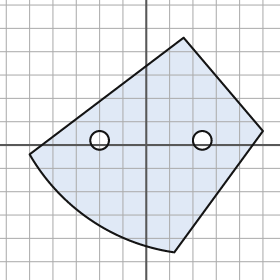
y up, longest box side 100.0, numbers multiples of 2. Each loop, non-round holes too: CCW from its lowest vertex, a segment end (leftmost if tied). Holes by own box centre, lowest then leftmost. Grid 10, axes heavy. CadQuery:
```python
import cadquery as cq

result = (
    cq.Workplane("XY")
    .moveTo(12.0, -46.0)
    .lineTo(50.0, 6.0)
    .lineTo(16.0, 46.0)
    .lineTo(-50.0, -4.0)
    .threePointArc((-24.0, -32.0), (12.0, -46.0))
    .close()
    .moveTo(-20.0, 2.0)
    .circle(4.0)
    .moveTo(24.0, 2.0)
    .circle(4.0)
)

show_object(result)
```